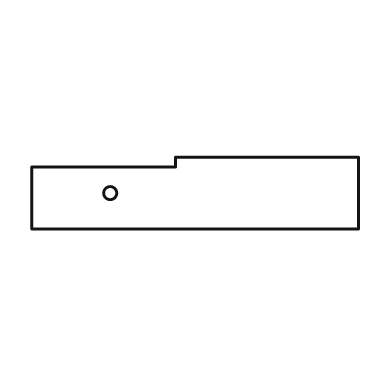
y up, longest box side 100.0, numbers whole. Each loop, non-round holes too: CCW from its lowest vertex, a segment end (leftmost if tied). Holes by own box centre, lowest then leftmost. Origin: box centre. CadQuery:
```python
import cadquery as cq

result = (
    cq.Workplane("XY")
    .moveTo(-50.0, -11.0)
    .lineTo(50.0, -11.0)
    .lineTo(50.0, 11.0)
    .lineTo(-6.0, 11.0)
    .lineTo(-6.0, 8.0)
    .lineTo(-50.0, 8.0)
    .close()
    .moveTo(-26.0, 0.0)
    .circle(2.0)
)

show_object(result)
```